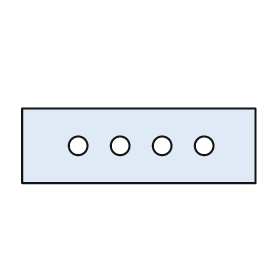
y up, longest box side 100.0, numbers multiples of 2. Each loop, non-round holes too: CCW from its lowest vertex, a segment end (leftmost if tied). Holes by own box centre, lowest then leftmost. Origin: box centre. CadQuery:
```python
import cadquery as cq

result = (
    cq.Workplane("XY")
    .moveTo(-50.0, -16.0)
    .lineTo(50.0, -16.0)
    .lineTo(50.0, 16.0)
    .lineTo(-50.0, 16.0)
    .close()
    .moveTo(-26.0, 0.0)
    .circle(4.0)
    .moveTo(-8.0, 0.0)
    .circle(4.0)
    .moveTo(10.0, 0.0)
    .circle(4.0)
    .moveTo(28.0, 0.0)
    .circle(4.0)
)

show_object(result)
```